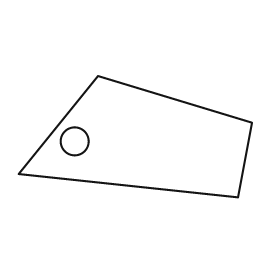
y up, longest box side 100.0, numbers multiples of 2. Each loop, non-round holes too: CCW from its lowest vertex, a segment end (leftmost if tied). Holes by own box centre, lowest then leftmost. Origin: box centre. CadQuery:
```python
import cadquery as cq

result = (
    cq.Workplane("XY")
    .moveTo(44.0, -26.0)
    .lineTo(50.0, 6.0)
    .lineTo(-16.0, 26.0)
    .lineTo(-50.0, -16.0)
    .close()
    .moveTo(-26.0, -2.0)
    .circle(6.0)
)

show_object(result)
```